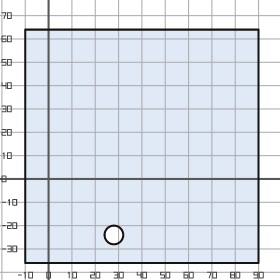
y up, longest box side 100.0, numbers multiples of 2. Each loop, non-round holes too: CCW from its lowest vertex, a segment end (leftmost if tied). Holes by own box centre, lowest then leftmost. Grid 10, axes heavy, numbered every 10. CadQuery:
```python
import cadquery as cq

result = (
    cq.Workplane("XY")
    .moveTo(-10.0, -36.0)
    .lineTo(90.0, -36.0)
    .lineTo(90.0, 64.0)
    .lineTo(-10.0, 64.0)
    .close()
    .moveTo(28.0, -24.0)
    .circle(4.0)
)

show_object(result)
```